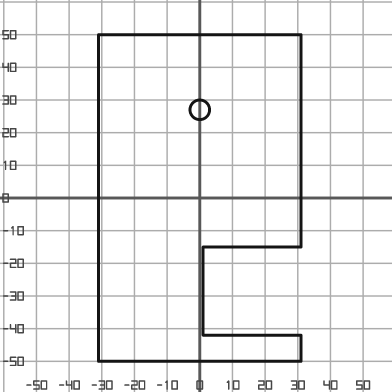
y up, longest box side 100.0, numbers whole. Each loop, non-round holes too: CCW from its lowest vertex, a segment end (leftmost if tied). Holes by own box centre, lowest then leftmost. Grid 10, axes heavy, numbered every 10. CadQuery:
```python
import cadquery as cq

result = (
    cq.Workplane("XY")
    .moveTo(-31.0, -50.0)
    .lineTo(31.0, -50.0)
    .lineTo(31.0, -42.0)
    .lineTo(1.0, -42.0)
    .lineTo(1.0, -15.0)
    .lineTo(31.0, -15.0)
    .lineTo(31.0, 50.0)
    .lineTo(-31.0, 50.0)
    .close()
    .moveTo(0.0, 27.0)
    .circle(3.0)
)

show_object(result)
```